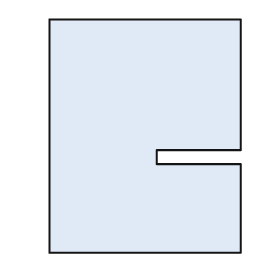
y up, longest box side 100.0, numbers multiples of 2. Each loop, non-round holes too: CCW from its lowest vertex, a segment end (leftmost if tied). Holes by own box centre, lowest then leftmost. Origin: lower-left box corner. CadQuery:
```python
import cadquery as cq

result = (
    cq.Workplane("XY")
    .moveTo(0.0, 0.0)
    .lineTo(82.0, 0.0)
    .lineTo(82.0, 38.0)
    .lineTo(46.0, 38.0)
    .lineTo(46.0, 44.0)
    .lineTo(82.0, 44.0)
    .lineTo(82.0, 100.0)
    .lineTo(0.0, 100.0)
    .close()
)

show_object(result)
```